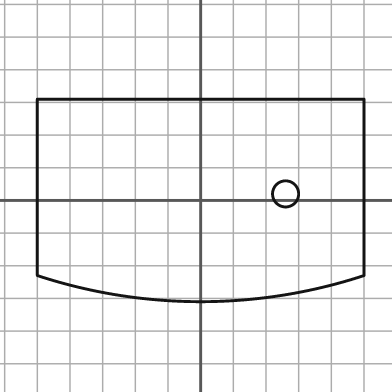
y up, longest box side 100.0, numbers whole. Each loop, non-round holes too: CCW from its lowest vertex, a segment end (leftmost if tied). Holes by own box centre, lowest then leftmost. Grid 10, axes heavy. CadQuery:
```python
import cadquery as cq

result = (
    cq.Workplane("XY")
    .moveTo(-50.0, -23.0)
    .threePointArc((0.0, -31.0), (50.0, -23.0))
    .lineTo(50.0, 31.0)
    .lineTo(-50.0, 31.0)
    .close()
    .moveTo(26.0, 2.0)
    .circle(4.0)
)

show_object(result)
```